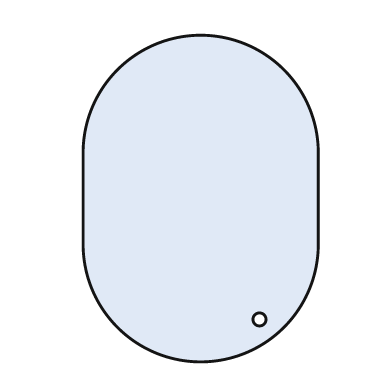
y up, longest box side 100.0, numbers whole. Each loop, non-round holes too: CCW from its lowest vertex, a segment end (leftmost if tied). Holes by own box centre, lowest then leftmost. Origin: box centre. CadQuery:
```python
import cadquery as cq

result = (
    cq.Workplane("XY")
    .moveTo(-36.0, -14.0)
    .threePointArc((0.0, -50.0), (36.0, -14.0))
    .lineTo(36.0, 14.0)
    .threePointArc((0.0, 50.0), (-36.0, 14.0))
    .close()
    .moveTo(18.0, -37.0)
    .circle(2.0)
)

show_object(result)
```